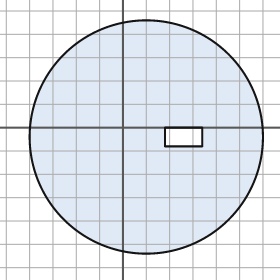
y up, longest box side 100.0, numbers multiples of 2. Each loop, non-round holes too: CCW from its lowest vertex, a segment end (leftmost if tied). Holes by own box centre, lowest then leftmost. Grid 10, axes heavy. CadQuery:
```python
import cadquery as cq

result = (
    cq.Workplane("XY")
    .moveTo(10.0, -4.0)
    .circle(50.0)
    .moveTo(18.0, -8.0)
    .lineTo(34.0, -8.0)
    .lineTo(34.0, 0.0)
    .lineTo(18.0, 0.0)
    .close()
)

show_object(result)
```